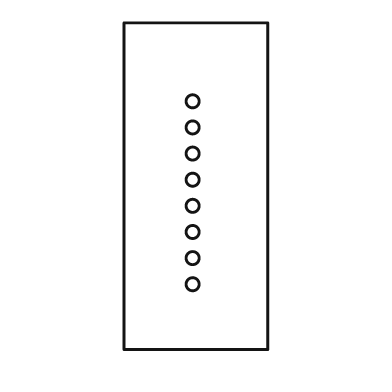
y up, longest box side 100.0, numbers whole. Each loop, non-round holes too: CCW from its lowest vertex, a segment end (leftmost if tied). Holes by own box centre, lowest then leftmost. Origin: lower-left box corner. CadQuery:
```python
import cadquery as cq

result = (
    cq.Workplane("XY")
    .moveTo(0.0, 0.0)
    .lineTo(44.0, 0.0)
    .lineTo(44.0, 100.0)
    .lineTo(0.0, 100.0)
    .close()
    .moveTo(21.0, 20.0)
    .circle(2.0)
    .moveTo(21.0, 28.0)
    .circle(2.0)
    .moveTo(21.0, 36.0)
    .circle(2.0)
    .moveTo(21.0, 44.0)
    .circle(2.0)
    .moveTo(21.0, 52.0)
    .circle(2.0)
    .moveTo(21.0, 60.0)
    .circle(2.0)
    .moveTo(21.0, 68.0)
    .circle(2.0)
    .moveTo(21.0, 76.0)
    .circle(2.0)
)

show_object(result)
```